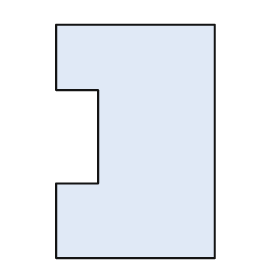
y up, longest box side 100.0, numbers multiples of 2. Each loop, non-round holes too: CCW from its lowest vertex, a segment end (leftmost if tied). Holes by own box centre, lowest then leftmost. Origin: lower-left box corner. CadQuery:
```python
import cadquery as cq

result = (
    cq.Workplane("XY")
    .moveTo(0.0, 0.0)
    .lineTo(68.0, 0.0)
    .lineTo(68.0, 100.0)
    .lineTo(0.0, 100.0)
    .lineTo(0.0, 72.0)
    .lineTo(18.0, 72.0)
    .lineTo(18.0, 32.0)
    .lineTo(0.0, 32.0)
    .close()
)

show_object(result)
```